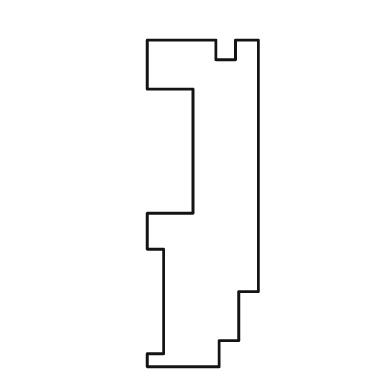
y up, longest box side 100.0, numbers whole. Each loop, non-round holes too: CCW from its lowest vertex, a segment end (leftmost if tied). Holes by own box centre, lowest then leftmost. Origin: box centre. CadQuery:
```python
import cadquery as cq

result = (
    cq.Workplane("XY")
    .moveTo(-17.0, -50.0)
    .lineTo(5.0, -50.0)
    .lineTo(5.0, -42.0)
    .lineTo(11.0, -42.0)
    .lineTo(11.0, -27.0)
    .lineTo(17.0, -27.0)
    .lineTo(17.0, 50.0)
    .lineTo(10.0, 50.0)
    .lineTo(10.0, 44.0)
    .lineTo(4.0, 44.0)
    .lineTo(4.0, 50.0)
    .lineTo(-17.0, 50.0)
    .lineTo(-17.0, 35.0)
    .lineTo(-3.0, 35.0)
    .lineTo(-3.0, -3.0)
    .lineTo(-17.0, -3.0)
    .lineTo(-17.0, -14.0)
    .lineTo(-12.0, -14.0)
    .lineTo(-12.0, -46.0)
    .lineTo(-17.0, -46.0)
    .close()
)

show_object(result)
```